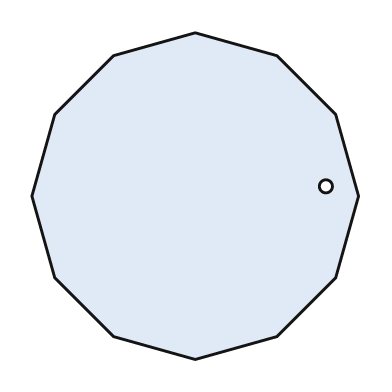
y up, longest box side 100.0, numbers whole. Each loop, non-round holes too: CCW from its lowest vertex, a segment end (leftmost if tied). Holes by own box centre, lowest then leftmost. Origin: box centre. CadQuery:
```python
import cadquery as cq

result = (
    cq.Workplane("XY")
    .moveTo(0.0, -50.0)
    .lineTo(25.0, -43.0)
    .lineTo(43.0, -25.0)
    .lineTo(50.0, 0.0)
    .lineTo(43.0, 25.0)
    .lineTo(25.0, 43.0)
    .lineTo(0.0, 50.0)
    .lineTo(-25.0, 43.0)
    .lineTo(-43.0, 25.0)
    .lineTo(-50.0, 0.0)
    .lineTo(-43.0, -25.0)
    .lineTo(-25.0, -43.0)
    .close()
    .moveTo(40.0, 3.0)
    .circle(2.0)
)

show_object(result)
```